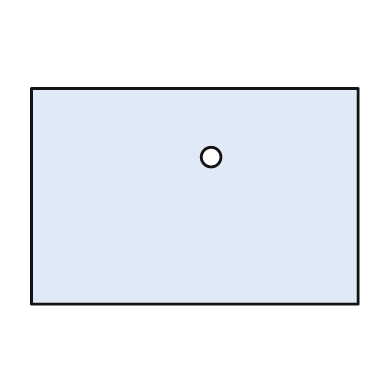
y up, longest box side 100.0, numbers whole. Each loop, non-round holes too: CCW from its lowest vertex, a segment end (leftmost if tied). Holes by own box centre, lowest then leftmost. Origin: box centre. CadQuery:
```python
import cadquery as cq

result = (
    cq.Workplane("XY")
    .moveTo(-50.0, -33.0)
    .lineTo(50.0, -33.0)
    .lineTo(50.0, 33.0)
    .lineTo(-50.0, 33.0)
    .close()
    .moveTo(5.0, 12.0)
    .circle(3.0)
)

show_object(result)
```